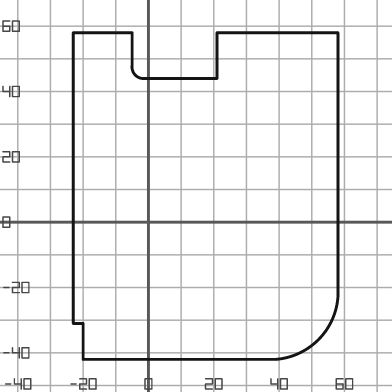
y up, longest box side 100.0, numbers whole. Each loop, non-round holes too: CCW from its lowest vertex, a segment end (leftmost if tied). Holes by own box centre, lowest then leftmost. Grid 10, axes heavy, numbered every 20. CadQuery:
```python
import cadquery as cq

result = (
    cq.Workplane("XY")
    .moveTo(-20.0, -42.0)
    .lineTo(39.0, -42.0)
    .threePointArc((52.0, -36.0), (58.0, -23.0))
    .lineTo(58.0, 58.0)
    .lineTo(21.0, 58.0)
    .lineTo(21.0, 44.0)
    .lineTo(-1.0, 44.0)
    .threePointArc((-4.0, 45.0), (-5.0, 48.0))
    .lineTo(-5.0, 58.0)
    .lineTo(-23.0, 58.0)
    .lineTo(-23.0, -31.0)
    .lineTo(-20.0, -31.0)
    .close()
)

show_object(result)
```